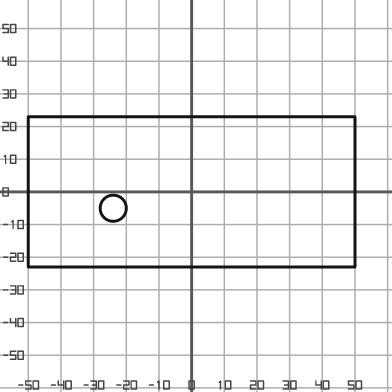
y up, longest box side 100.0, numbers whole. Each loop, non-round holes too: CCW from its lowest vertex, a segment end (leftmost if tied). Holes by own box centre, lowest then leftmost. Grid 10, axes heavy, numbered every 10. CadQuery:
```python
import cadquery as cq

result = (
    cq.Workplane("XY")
    .moveTo(-50.0, -23.0)
    .lineTo(50.0, -23.0)
    .lineTo(50.0, 23.0)
    .lineTo(-50.0, 23.0)
    .close()
    .moveTo(-24.0, -5.0)
    .circle(4.0)
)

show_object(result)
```